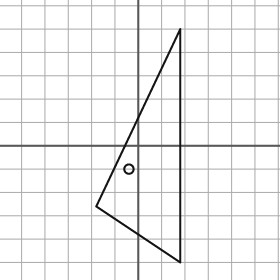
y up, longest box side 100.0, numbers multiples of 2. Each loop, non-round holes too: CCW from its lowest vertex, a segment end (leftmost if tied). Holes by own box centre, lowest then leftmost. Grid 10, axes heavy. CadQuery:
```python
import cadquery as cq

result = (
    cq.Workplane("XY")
    .moveTo(18.0, -50.0)
    .lineTo(18.0, 50.0)
    .lineTo(-18.0, -26.0)
    .close()
    .moveTo(-4.0, -10.0)
    .circle(2.0)
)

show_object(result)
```